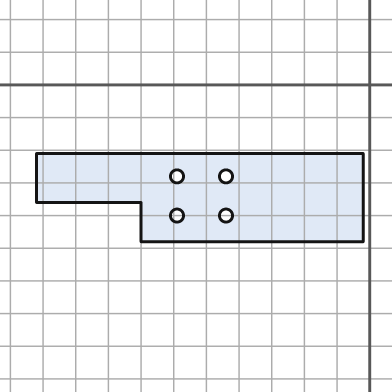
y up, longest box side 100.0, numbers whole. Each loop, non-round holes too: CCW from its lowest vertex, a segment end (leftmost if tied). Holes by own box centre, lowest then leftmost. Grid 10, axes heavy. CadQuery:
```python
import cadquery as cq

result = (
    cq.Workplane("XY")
    .moveTo(-70.0, -48.0)
    .lineTo(-2.0, -48.0)
    .lineTo(-2.0, -21.0)
    .lineTo(-102.0, -21.0)
    .lineTo(-102.0, -36.0)
    .lineTo(-70.0, -36.0)
    .close()
    .moveTo(-59.0, -40.0)
    .circle(2.0)
    .moveTo(-44.0, -40.0)
    .circle(2.0)
    .moveTo(-59.0, -28.0)
    .circle(2.0)
    .moveTo(-44.0, -28.0)
    .circle(2.0)
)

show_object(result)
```